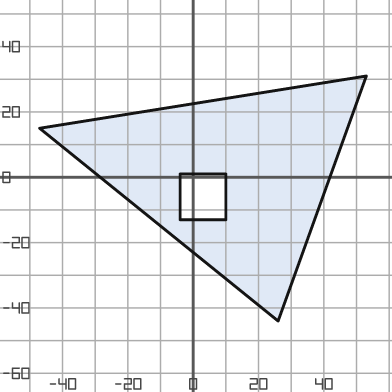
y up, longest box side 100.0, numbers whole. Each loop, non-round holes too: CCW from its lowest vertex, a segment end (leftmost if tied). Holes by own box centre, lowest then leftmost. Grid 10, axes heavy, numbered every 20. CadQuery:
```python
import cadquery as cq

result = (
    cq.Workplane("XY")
    .moveTo(26.0, -44.0)
    .lineTo(53.0, 31.0)
    .lineTo(-47.0, 15.0)
    .close()
    .moveTo(-4.0, -13.0)
    .lineTo(10.0, -13.0)
    .lineTo(10.0, 1.0)
    .lineTo(-4.0, 1.0)
    .close()
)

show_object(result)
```